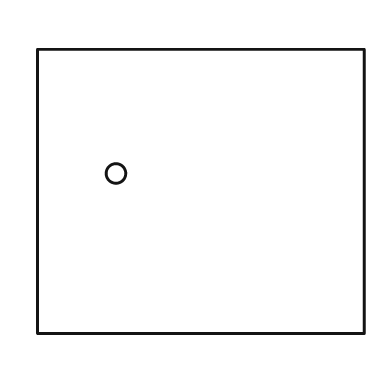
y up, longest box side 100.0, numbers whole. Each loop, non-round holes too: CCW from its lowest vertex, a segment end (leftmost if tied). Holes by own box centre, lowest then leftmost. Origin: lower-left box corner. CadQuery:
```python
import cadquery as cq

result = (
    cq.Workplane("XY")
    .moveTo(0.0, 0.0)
    .lineTo(100.0, 0.0)
    .lineTo(100.0, 87.0)
    .lineTo(0.0, 87.0)
    .close()
    .moveTo(24.0, 49.0)
    .circle(3.0)
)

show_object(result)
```